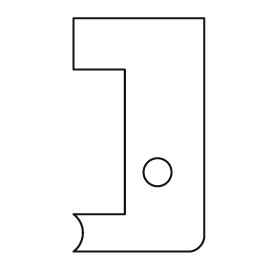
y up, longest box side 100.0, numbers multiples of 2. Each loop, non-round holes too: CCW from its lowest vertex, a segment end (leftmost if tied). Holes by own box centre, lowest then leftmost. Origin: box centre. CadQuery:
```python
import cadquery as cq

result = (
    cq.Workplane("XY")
    .moveTo(-28.0, -50.0)
    .lineTo(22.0, -50.0)
    .threePointArc((26.0, -48.0), (28.0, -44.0))
    .lineTo(28.0, 50.0)
    .lineTo(-28.0, 50.0)
    .lineTo(-28.0, 28.0)
    .lineTo(-6.0, 28.0)
    .lineTo(-6.0, -34.0)
    .lineTo(-28.0, -34.0)
    .threePointArc((-24.0, -42.0), (-28.0, -50.0))
    .close()
    .moveTo(8.0, -16.0)
    .circle(6.0)
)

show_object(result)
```